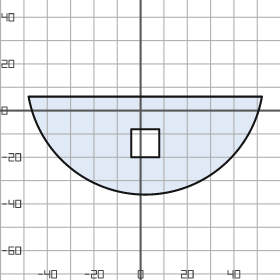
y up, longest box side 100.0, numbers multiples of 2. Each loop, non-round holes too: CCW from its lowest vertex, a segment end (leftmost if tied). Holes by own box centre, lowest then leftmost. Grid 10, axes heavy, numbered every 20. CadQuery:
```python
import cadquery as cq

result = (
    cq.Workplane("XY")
    .moveTo(-48.0, 6.0)
    .threePointArc((2.0, -36.0), (52.0, 6.0))
    .close()
    .moveTo(-4.0, -20.0)
    .lineTo(8.0, -20.0)
    .lineTo(8.0, -8.0)
    .lineTo(-4.0, -8.0)
    .close()
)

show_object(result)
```